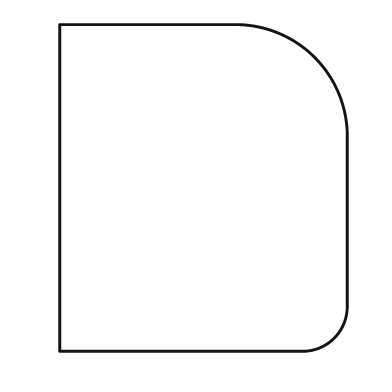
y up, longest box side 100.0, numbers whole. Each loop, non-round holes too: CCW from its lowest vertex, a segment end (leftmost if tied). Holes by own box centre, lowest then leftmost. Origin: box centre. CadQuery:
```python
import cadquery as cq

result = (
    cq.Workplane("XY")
    .moveTo(-44.0, -50.0)
    .lineTo(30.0, -50.0)
    .threePointArc((40.0, -46.0), (44.0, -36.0))
    .lineTo(44.0, 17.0)
    .threePointArc((34.0, 40.0), (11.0, 50.0))
    .lineTo(-44.0, 50.0)
    .close()
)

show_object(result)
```